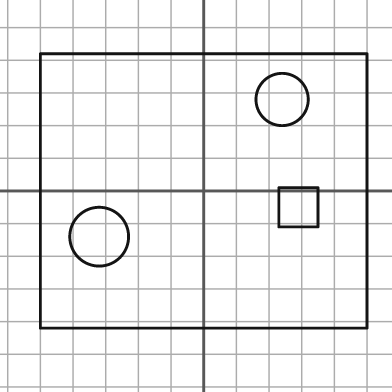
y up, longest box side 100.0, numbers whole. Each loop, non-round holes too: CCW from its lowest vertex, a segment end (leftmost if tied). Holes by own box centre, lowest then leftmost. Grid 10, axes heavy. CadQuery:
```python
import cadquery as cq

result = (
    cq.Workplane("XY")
    .moveTo(-50.0, -42.0)
    .lineTo(50.0, -42.0)
    .lineTo(50.0, 42.0)
    .lineTo(-50.0, 42.0)
    .close()
    .moveTo(-32.0, -14.0)
    .circle(9.0)
    .moveTo(23.0, -11.0)
    .lineTo(35.0, -11.0)
    .lineTo(35.0, 1.0)
    .lineTo(23.0, 1.0)
    .close()
    .moveTo(24.0, 28.0)
    .circle(8.0)
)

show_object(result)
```